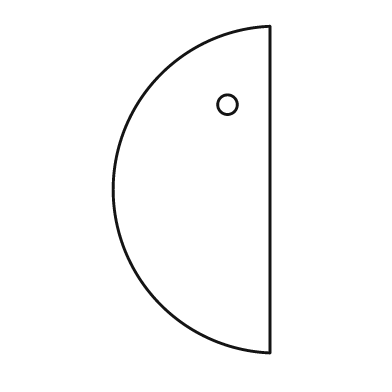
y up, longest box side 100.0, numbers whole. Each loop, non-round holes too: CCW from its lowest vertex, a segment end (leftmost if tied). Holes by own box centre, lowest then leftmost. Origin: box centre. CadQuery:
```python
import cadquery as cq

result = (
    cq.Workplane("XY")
    .moveTo(24.0, -50.0)
    .lineTo(24.0, 50.0)
    .threePointArc((-24.0, 0.0), (24.0, -50.0))
    .close()
    .moveTo(11.0, 26.0)
    .circle(3.0)
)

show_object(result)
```